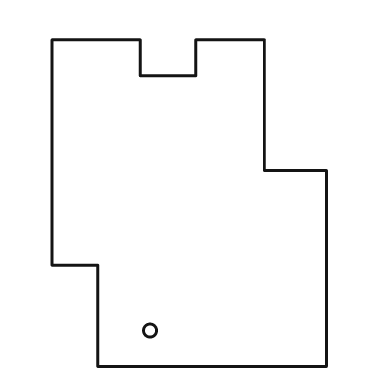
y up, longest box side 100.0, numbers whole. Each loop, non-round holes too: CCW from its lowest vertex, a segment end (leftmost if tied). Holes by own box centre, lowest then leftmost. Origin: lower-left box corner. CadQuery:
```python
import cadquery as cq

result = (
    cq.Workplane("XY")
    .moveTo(14.0, 0.0)
    .lineTo(84.0, 0.0)
    .lineTo(84.0, 60.0)
    .lineTo(65.0, 60.0)
    .lineTo(65.0, 100.0)
    .lineTo(44.0, 100.0)
    .lineTo(44.0, 89.0)
    .lineTo(27.0, 89.0)
    .lineTo(27.0, 100.0)
    .lineTo(0.0, 100.0)
    .lineTo(0.0, 31.0)
    .lineTo(14.0, 31.0)
    .close()
    .moveTo(30.0, 11.0)
    .circle(2.0)
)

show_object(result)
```